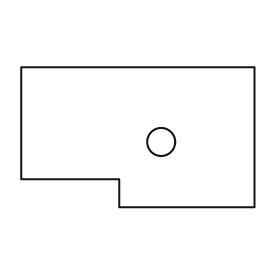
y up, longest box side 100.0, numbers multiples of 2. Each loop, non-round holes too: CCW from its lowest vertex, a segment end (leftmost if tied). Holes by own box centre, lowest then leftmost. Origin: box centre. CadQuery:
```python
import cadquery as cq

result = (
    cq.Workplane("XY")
    .moveTo(-8.0, -30.0)
    .lineTo(50.0, -30.0)
    .lineTo(50.0, 30.0)
    .lineTo(-50.0, 30.0)
    .lineTo(-50.0, -18.0)
    .lineTo(-8.0, -18.0)
    .close()
    .moveTo(10.0, -2.0)
    .circle(6.0)
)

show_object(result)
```